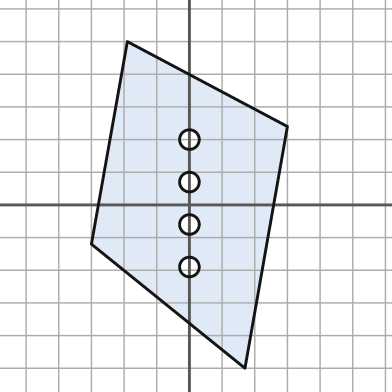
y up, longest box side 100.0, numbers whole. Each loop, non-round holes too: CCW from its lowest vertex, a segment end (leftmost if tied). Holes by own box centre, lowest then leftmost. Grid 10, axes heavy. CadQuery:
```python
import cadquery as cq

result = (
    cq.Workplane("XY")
    .moveTo(17.0, -50.0)
    .lineTo(30.0, 24.0)
    .lineTo(-19.0, 50.0)
    .lineTo(-30.0, -12.0)
    .close()
    .moveTo(0.0, -19.0)
    .circle(3.0)
    .moveTo(0.0, -6.0)
    .circle(3.0)
    .moveTo(0.0, 7.0)
    .circle(3.0)
    .moveTo(0.0, 20.0)
    .circle(3.0)
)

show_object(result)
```